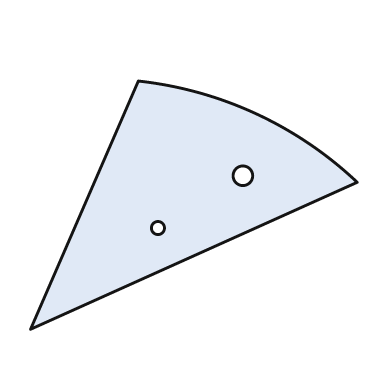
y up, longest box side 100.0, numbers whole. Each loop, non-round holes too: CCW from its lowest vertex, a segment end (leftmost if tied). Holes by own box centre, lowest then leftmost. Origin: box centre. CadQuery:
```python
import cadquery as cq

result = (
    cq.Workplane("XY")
    .moveTo(-50.0, -38.0)
    .lineTo(50.0, 7.0)
    .threePointArc((19.0, 28.0), (-17.0, 38.0))
    .close()
    .moveTo(-11.0, -7.0)
    .circle(2.0)
    .moveTo(15.0, 9.0)
    .circle(3.0)
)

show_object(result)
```